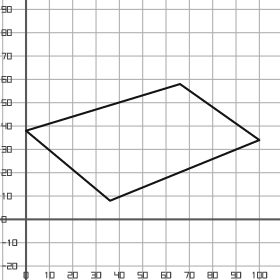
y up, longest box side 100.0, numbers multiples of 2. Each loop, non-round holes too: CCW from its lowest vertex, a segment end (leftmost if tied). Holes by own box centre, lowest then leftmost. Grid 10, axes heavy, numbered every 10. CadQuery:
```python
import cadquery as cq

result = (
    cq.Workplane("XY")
    .moveTo(36.0, 8.0)
    .lineTo(100.0, 34.0)
    .lineTo(66.0, 58.0)
    .lineTo(0.0, 38.0)
    .close()
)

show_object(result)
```